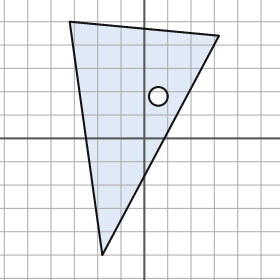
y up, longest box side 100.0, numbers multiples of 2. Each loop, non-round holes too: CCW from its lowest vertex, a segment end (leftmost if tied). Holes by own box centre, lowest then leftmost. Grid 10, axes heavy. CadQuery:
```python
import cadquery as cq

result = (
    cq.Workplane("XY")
    .moveTo(-18.0, -50.0)
    .lineTo(32.0, 44.0)
    .lineTo(-32.0, 50.0)
    .close()
    .moveTo(6.0, 18.0)
    .circle(4.0)
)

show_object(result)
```